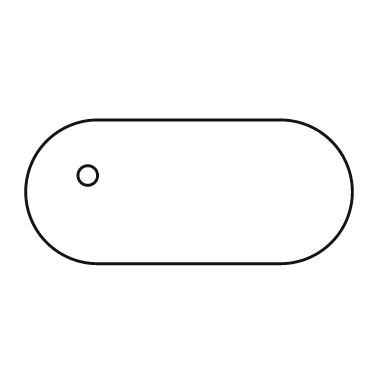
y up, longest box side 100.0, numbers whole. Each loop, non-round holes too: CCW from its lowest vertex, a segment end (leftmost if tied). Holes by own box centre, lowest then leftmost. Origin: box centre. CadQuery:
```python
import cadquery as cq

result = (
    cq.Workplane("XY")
    .moveTo(-28.0, -22.0)
    .lineTo(28.0, -22.0)
    .threePointArc((50.0, 0.0), (28.0, 22.0))
    .lineTo(-28.0, 22.0)
    .threePointArc((-50.0, 0.0), (-28.0, -22.0))
    .close()
    .moveTo(-31.0, 5.0)
    .circle(3.0)
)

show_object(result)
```